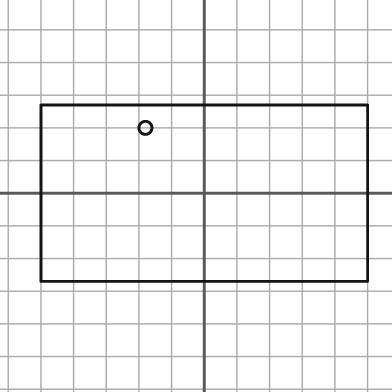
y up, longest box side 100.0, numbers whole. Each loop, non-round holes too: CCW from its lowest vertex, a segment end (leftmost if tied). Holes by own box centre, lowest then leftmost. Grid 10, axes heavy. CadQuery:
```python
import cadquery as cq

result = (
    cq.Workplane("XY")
    .moveTo(-50.0, -27.0)
    .lineTo(50.0, -27.0)
    .lineTo(50.0, 27.0)
    .lineTo(-50.0, 27.0)
    .close()
    .moveTo(-18.0, 20.0)
    .circle(2.0)
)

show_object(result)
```